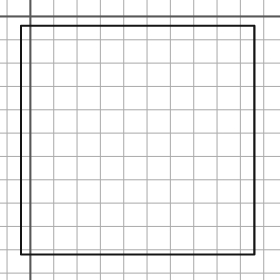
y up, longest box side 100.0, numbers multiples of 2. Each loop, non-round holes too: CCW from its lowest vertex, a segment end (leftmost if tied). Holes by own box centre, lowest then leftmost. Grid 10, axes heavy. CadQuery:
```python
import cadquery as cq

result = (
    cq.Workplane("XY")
    .moveTo(-4.0, -102.0)
    .lineTo(96.0, -102.0)
    .lineTo(96.0, -4.0)
    .lineTo(-4.0, -4.0)
    .close()
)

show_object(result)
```